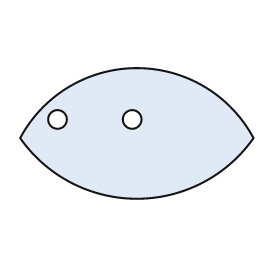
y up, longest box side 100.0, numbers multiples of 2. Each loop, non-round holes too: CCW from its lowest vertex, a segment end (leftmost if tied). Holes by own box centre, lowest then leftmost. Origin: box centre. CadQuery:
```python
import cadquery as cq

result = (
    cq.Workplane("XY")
    .moveTo(-50.0, -2.0)
    .threePointArc((0.0, -28.0), (50.0, -2.0))
    .threePointArc((0.0, 28.0), (-50.0, -2.0))
    .close()
    .moveTo(-34.0, 6.0)
    .circle(4.0)
    .moveTo(-2.0, 6.0)
    .circle(4.0)
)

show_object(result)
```